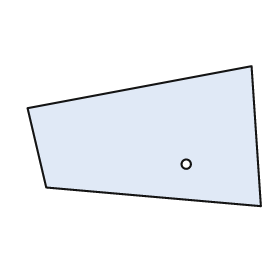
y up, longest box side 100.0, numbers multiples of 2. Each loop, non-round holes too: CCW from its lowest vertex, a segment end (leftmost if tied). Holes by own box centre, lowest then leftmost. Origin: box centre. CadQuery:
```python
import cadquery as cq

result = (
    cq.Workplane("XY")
    .moveTo(50.0, -30.0)
    .lineTo(46.0, 30.0)
    .lineTo(-50.0, 12.0)
    .lineTo(-42.0, -22.0)
    .close()
    .moveTo(18.0, -12.0)
    .circle(2.0)
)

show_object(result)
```